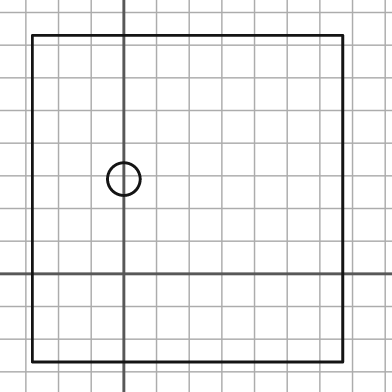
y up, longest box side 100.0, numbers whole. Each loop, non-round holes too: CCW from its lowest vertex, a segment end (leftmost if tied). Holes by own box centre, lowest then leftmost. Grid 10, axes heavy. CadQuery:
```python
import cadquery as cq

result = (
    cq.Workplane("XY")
    .moveTo(-28.0, -27.0)
    .lineTo(67.0, -27.0)
    .lineTo(67.0, 73.0)
    .lineTo(-28.0, 73.0)
    .close()
    .moveTo(0.0, 29.0)
    .circle(5.0)
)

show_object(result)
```